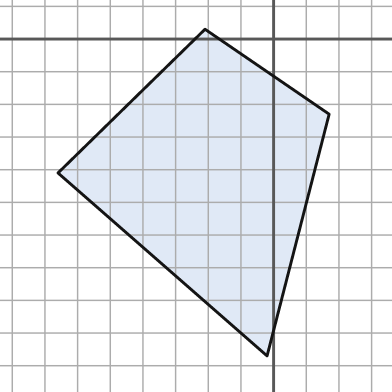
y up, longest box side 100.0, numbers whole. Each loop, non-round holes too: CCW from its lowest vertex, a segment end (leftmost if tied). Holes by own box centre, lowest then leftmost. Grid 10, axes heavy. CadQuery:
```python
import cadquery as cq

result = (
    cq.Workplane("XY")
    .moveTo(-2.0, -97.0)
    .lineTo(17.0, -23.0)
    .lineTo(-21.0, 3.0)
    .lineTo(-66.0, -41.0)
    .close()
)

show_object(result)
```